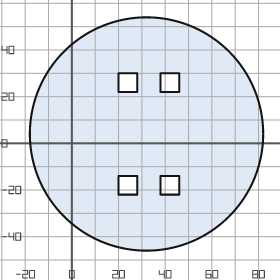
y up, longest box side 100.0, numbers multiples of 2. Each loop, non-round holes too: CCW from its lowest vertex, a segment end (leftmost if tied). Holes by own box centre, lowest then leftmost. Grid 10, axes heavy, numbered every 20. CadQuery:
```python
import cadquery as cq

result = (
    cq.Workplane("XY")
    .moveTo(32.0, 4.0)
    .circle(50.0)
    .moveTo(20.0, -22.0)
    .lineTo(28.0, -22.0)
    .lineTo(28.0, -14.0)
    .lineTo(20.0, -14.0)
    .close()
    .moveTo(38.0, -22.0)
    .lineTo(46.0, -22.0)
    .lineTo(46.0, -14.0)
    .lineTo(38.0, -14.0)
    .close()
    .moveTo(20.0, 22.0)
    .lineTo(28.0, 22.0)
    .lineTo(28.0, 30.0)
    .lineTo(20.0, 30.0)
    .close()
    .moveTo(38.0, 22.0)
    .lineTo(46.0, 22.0)
    .lineTo(46.0, 30.0)
    .lineTo(38.0, 30.0)
    .close()
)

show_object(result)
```